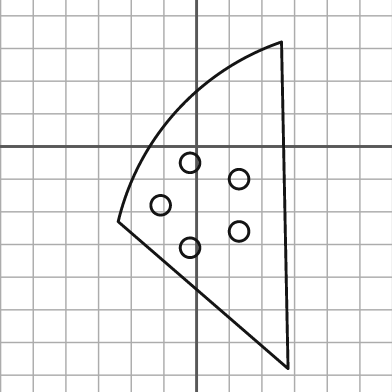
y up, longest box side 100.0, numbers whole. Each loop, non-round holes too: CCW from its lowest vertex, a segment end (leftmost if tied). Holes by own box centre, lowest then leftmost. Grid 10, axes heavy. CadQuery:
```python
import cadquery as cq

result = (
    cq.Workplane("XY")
    .moveTo(28.0, -68.0)
    .lineTo(26.0, 32.0)
    .threePointArc((-6.0, 11.0), (-24.0, -23.0))
    .close()
    .moveTo(-2.0, -31.0)
    .circle(3.0)
    .moveTo(13.0, -26.0)
    .circle(3.0)
    .moveTo(-11.0, -18.0)
    .circle(3.0)
    .moveTo(13.0, -10.0)
    .circle(3.0)
    .moveTo(-2.0, -5.0)
    .circle(3.0)
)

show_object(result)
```